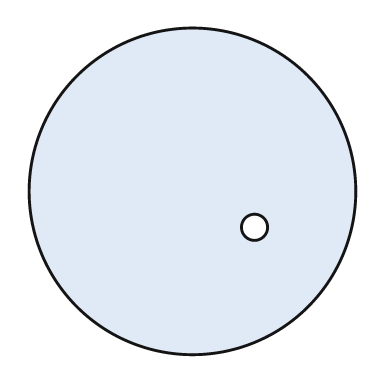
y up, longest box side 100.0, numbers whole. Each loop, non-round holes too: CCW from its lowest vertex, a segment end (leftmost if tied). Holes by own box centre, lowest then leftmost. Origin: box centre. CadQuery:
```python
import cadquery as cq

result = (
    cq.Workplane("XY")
    .moveTo(0.0, 0.0)
    .circle(50.0)
    .moveTo(19.0, -11.0)
    .circle(4.0)
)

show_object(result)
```